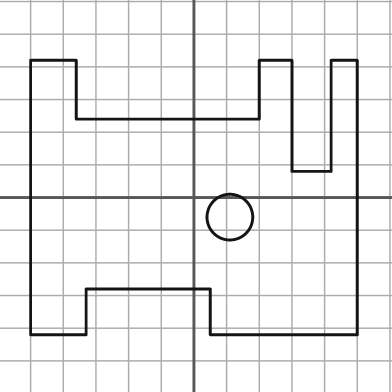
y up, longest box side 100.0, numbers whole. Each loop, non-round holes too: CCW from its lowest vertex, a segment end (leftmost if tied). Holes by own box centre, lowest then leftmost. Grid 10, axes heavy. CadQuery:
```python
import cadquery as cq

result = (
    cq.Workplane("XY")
    .moveTo(-50.0, -42.0)
    .lineTo(-33.0, -42.0)
    .lineTo(-33.0, -28.0)
    .lineTo(5.0, -28.0)
    .lineTo(5.0, -42.0)
    .lineTo(50.0, -42.0)
    .lineTo(50.0, 42.0)
    .lineTo(42.0, 42.0)
    .lineTo(42.0, 8.0)
    .lineTo(30.0, 8.0)
    .lineTo(30.0, 42.0)
    .lineTo(20.0, 42.0)
    .lineTo(20.0, 24.0)
    .lineTo(-36.0, 24.0)
    .lineTo(-36.0, 42.0)
    .lineTo(-50.0, 42.0)
    .close()
    .moveTo(11.0, -6.0)
    .circle(7.0)
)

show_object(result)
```